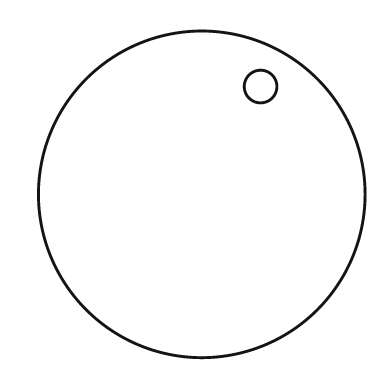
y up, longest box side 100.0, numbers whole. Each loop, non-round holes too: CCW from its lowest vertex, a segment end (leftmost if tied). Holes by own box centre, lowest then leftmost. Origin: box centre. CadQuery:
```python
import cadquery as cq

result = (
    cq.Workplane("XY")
    .moveTo(0.0, 0.0)
    .circle(50.0)
    .moveTo(18.0, 33.0)
    .circle(5.0)
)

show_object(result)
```